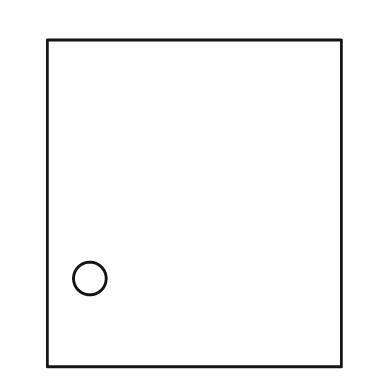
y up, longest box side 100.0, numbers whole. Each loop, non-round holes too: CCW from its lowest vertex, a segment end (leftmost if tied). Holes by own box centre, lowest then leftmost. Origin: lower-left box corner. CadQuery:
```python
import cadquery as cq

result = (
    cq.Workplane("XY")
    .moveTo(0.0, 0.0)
    .lineTo(90.0, 0.0)
    .lineTo(90.0, 100.0)
    .lineTo(0.0, 100.0)
    .close()
    .moveTo(13.0, 27.0)
    .circle(5.0)
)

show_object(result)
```